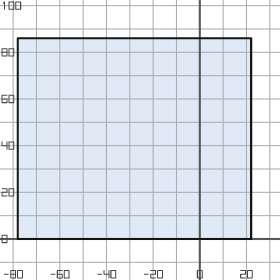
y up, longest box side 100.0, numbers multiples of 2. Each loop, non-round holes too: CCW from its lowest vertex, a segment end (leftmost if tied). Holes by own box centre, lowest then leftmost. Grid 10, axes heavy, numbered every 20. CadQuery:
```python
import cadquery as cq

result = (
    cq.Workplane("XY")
    .moveTo(-78.0, 0.0)
    .lineTo(22.0, 0.0)
    .lineTo(22.0, 86.0)
    .lineTo(-78.0, 86.0)
    .close()
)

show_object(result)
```